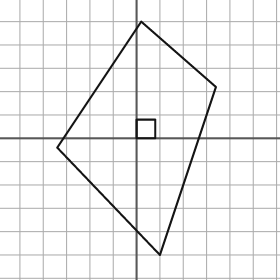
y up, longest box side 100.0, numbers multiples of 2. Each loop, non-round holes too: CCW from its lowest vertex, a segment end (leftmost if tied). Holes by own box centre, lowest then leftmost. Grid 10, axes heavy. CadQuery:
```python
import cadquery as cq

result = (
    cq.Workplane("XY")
    .moveTo(10.0, -50.0)
    .lineTo(34.0, 22.0)
    .lineTo(2.0, 50.0)
    .lineTo(-34.0, -4.0)
    .close()
    .moveTo(0.0, 0.0)
    .lineTo(8.0, 0.0)
    .lineTo(8.0, 8.0)
    .lineTo(0.0, 8.0)
    .close()
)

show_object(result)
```